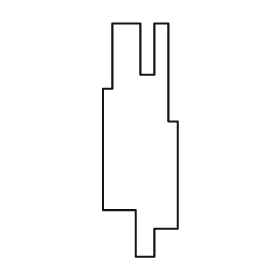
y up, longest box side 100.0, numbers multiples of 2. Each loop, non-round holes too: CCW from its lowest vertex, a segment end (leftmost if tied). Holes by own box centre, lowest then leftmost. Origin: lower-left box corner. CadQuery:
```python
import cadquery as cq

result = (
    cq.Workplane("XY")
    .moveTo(14.0, 0.0)
    .lineTo(22.0, 0.0)
    .lineTo(22.0, 12.0)
    .lineTo(32.0, 12.0)
    .lineTo(32.0, 58.0)
    .lineTo(28.0, 58.0)
    .lineTo(28.0, 100.0)
    .lineTo(22.0, 100.0)
    .lineTo(22.0, 78.0)
    .lineTo(16.0, 78.0)
    .lineTo(16.0, 100.0)
    .lineTo(4.0, 100.0)
    .lineTo(4.0, 72.0)
    .lineTo(0.0, 72.0)
    .lineTo(0.0, 20.0)
    .lineTo(14.0, 20.0)
    .close()
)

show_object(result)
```